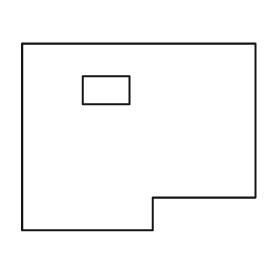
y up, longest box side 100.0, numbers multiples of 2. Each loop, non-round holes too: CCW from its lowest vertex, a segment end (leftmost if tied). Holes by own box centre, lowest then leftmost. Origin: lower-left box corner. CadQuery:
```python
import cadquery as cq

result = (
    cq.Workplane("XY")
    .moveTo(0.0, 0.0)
    .lineTo(56.0, 0.0)
    .lineTo(56.0, 14.0)
    .lineTo(100.0, 14.0)
    .lineTo(100.0, 80.0)
    .lineTo(0.0, 80.0)
    .close()
    .moveTo(26.0, 54.0)
    .lineTo(46.0, 54.0)
    .lineTo(46.0, 66.0)
    .lineTo(26.0, 66.0)
    .close()
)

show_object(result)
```